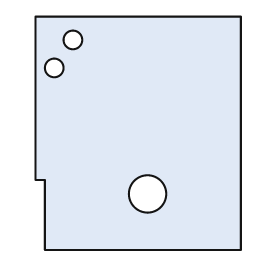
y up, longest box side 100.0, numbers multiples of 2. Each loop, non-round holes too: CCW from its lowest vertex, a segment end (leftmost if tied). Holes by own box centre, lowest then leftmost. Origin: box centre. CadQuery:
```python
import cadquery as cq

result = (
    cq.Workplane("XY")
    .moveTo(-40.0, -50.0)
    .lineTo(44.0, -50.0)
    .lineTo(44.0, 50.0)
    .lineTo(-44.0, 50.0)
    .lineTo(-44.0, -20.0)
    .lineTo(-40.0, -20.0)
    .close()
    .moveTo(4.0, -26.0)
    .circle(8.0)
    .moveTo(-36.0, 28.0)
    .circle(4.0)
    .moveTo(-28.0, 40.0)
    .circle(4.0)
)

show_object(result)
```